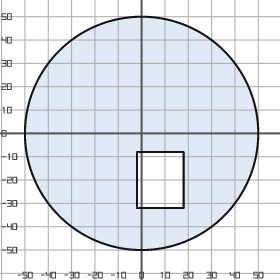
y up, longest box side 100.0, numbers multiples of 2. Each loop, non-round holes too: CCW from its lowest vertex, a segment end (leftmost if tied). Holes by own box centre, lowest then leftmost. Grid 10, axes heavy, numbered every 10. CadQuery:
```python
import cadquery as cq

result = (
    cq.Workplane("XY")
    .moveTo(0.0, 0.0)
    .circle(50.0)
    .moveTo(-2.0, -32.0)
    .lineTo(18.0, -32.0)
    .lineTo(18.0, -8.0)
    .lineTo(-2.0, -8.0)
    .close()
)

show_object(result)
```